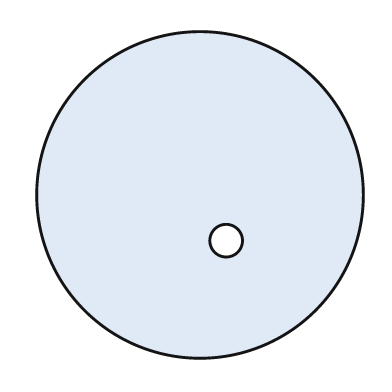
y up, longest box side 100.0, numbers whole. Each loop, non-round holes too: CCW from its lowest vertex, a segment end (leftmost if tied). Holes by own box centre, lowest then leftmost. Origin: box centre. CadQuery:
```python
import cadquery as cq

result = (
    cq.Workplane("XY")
    .moveTo(0.0, 0.0)
    .circle(50.0)
    .moveTo(8.0, -14.0)
    .circle(5.0)
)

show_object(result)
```